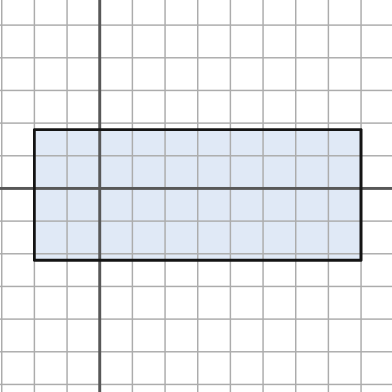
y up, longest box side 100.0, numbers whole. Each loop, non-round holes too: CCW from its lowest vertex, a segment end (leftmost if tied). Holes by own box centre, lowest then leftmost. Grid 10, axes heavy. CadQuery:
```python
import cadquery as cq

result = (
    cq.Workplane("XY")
    .moveTo(-20.0, -22.0)
    .lineTo(80.0, -22.0)
    .lineTo(80.0, 18.0)
    .lineTo(-20.0, 18.0)
    .close()
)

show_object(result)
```